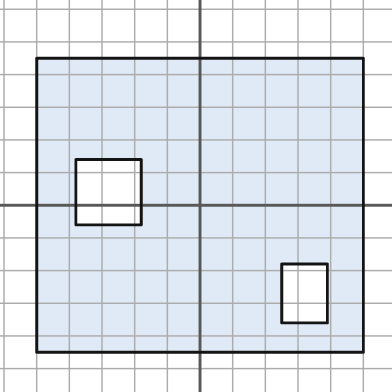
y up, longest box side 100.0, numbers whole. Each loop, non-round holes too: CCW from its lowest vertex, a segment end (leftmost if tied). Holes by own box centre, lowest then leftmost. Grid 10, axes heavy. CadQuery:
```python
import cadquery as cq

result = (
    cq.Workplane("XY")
    .moveTo(-50.0, -45.0)
    .lineTo(50.0, -45.0)
    .lineTo(50.0, 45.0)
    .lineTo(-50.0, 45.0)
    .close()
    .moveTo(25.0, -36.0)
    .lineTo(39.0, -36.0)
    .lineTo(39.0, -18.0)
    .lineTo(25.0, -18.0)
    .close()
    .moveTo(-38.0, -6.0)
    .lineTo(-18.0, -6.0)
    .lineTo(-18.0, 14.0)
    .lineTo(-38.0, 14.0)
    .close()
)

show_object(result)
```